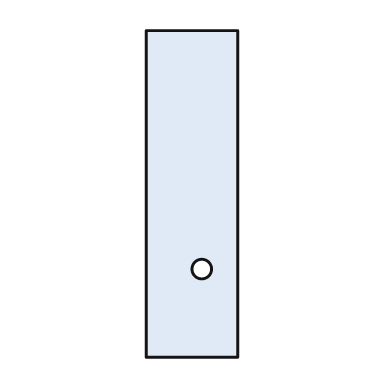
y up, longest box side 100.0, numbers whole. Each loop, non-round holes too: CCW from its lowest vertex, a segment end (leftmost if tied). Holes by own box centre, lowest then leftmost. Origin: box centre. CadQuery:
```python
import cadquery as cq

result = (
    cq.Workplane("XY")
    .moveTo(-14.0, -50.0)
    .lineTo(14.0, -50.0)
    .lineTo(14.0, 50.0)
    .lineTo(-14.0, 50.0)
    .close()
    .moveTo(3.0, -23.0)
    .circle(3.0)
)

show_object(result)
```